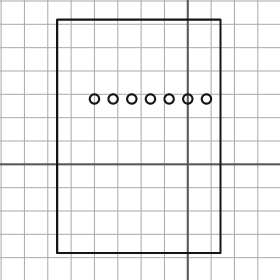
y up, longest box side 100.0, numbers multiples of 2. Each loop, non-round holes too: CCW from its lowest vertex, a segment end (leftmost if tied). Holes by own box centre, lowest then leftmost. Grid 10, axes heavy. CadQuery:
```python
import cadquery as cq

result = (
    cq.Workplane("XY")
    .moveTo(-56.0, -38.0)
    .lineTo(14.0, -38.0)
    .lineTo(14.0, 62.0)
    .lineTo(-56.0, 62.0)
    .close()
    .moveTo(-40.0, 28.0)
    .circle(2.0)
    .moveTo(-32.0, 28.0)
    .circle(2.0)
    .moveTo(-24.0, 28.0)
    .circle(2.0)
    .moveTo(-16.0, 28.0)
    .circle(2.0)
    .moveTo(-8.0, 28.0)
    .circle(2.0)
    .moveTo(0.0, 28.0)
    .circle(2.0)
    .moveTo(8.0, 28.0)
    .circle(2.0)
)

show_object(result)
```